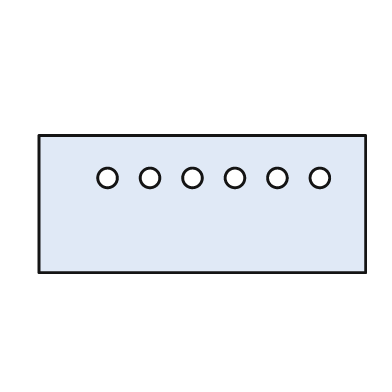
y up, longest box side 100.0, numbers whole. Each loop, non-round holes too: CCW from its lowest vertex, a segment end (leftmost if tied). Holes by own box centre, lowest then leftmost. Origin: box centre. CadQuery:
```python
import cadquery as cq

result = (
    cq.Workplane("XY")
    .moveTo(-50.0, -21.0)
    .lineTo(50.0, -21.0)
    .lineTo(50.0, 21.0)
    .lineTo(-50.0, 21.0)
    .close()
    .moveTo(-29.0, 8.0)
    .circle(3.0)
    .moveTo(-16.0, 8.0)
    .circle(3.0)
    .moveTo(-3.0, 8.0)
    .circle(3.0)
    .moveTo(10.0, 8.0)
    .circle(3.0)
    .moveTo(23.0, 8.0)
    .circle(3.0)
    .moveTo(36.0, 8.0)
    .circle(3.0)
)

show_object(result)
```